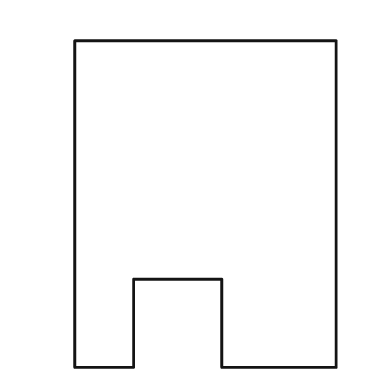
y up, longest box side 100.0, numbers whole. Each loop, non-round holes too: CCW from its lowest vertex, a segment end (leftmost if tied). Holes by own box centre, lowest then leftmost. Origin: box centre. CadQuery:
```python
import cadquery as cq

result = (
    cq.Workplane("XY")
    .moveTo(-40.0, -50.0)
    .lineTo(-22.0, -50.0)
    .lineTo(-22.0, -23.0)
    .lineTo(5.0, -23.0)
    .lineTo(5.0, -50.0)
    .lineTo(40.0, -50.0)
    .lineTo(40.0, 50.0)
    .lineTo(-40.0, 50.0)
    .close()
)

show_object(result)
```